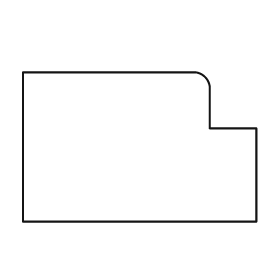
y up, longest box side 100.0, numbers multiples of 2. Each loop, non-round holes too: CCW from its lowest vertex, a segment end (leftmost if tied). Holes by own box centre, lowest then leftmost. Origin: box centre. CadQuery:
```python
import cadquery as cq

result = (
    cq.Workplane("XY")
    .moveTo(-50.0, -32.0)
    .lineTo(50.0, -32.0)
    .lineTo(50.0, 8.0)
    .lineTo(30.0, 8.0)
    .lineTo(30.0, 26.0)
    .threePointArc((28.0, 30.0), (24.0, 32.0))
    .lineTo(-50.0, 32.0)
    .close()
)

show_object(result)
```